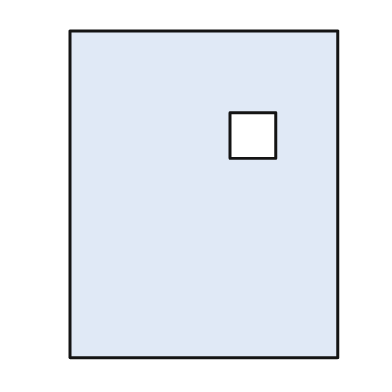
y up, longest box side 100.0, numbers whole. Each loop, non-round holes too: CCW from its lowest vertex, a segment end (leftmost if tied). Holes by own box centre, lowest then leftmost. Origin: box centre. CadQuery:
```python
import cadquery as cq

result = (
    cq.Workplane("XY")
    .moveTo(-41.0, -50.0)
    .lineTo(41.0, -50.0)
    .lineTo(41.0, 50.0)
    .lineTo(-41.0, 50.0)
    .close()
    .moveTo(8.0, 11.0)
    .lineTo(22.0, 11.0)
    .lineTo(22.0, 25.0)
    .lineTo(8.0, 25.0)
    .close()
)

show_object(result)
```